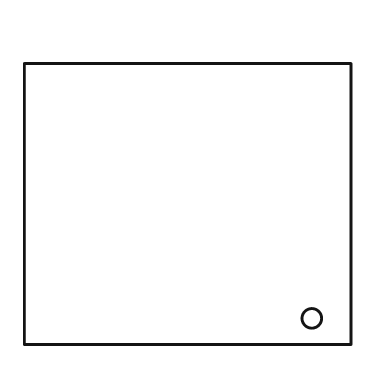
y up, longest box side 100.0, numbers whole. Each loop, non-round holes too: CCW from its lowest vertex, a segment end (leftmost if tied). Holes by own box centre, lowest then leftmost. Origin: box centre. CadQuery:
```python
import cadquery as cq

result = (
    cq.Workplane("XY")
    .moveTo(-50.0, -43.0)
    .lineTo(50.0, -43.0)
    .lineTo(50.0, 43.0)
    .lineTo(-50.0, 43.0)
    .close()
    .moveTo(38.0, -35.0)
    .circle(3.0)
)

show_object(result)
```